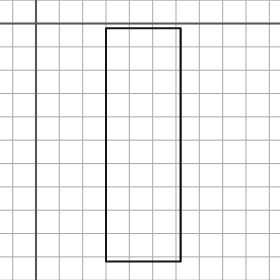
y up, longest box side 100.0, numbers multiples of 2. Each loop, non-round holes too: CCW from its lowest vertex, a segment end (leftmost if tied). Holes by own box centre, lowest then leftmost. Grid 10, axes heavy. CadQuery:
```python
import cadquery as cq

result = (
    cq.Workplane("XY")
    .moveTo(30.0, -102.0)
    .lineTo(62.0, -102.0)
    .lineTo(62.0, -2.0)
    .lineTo(30.0, -2.0)
    .close()
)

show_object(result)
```